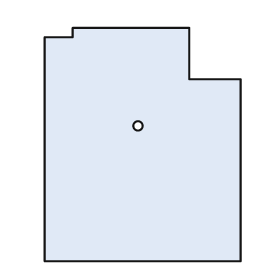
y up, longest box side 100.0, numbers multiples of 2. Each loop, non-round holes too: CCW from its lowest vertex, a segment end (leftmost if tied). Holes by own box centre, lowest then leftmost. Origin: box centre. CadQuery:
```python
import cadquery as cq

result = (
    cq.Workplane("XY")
    .moveTo(-42.0, -50.0)
    .lineTo(42.0, -50.0)
    .lineTo(42.0, 28.0)
    .lineTo(20.0, 28.0)
    .lineTo(20.0, 50.0)
    .lineTo(-30.0, 50.0)
    .lineTo(-30.0, 46.0)
    .lineTo(-42.0, 46.0)
    .close()
    .moveTo(-2.0, 8.0)
    .circle(2.0)
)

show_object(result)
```